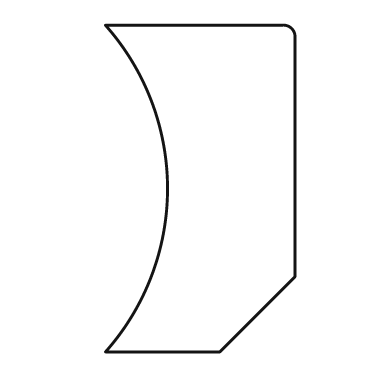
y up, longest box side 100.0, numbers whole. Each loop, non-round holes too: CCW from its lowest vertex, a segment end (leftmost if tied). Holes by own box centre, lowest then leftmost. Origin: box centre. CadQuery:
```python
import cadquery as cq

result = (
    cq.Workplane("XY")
    .moveTo(-29.0, -50.0)
    .lineTo(6.0, -50.0)
    .lineTo(29.0, -27.0)
    .lineTo(29.0, 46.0)
    .threePointArc((28.0, 49.0), (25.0, 50.0))
    .lineTo(-29.0, 50.0)
    .threePointArc((-10.0, 0.0), (-29.0, -50.0))
    .close()
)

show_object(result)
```